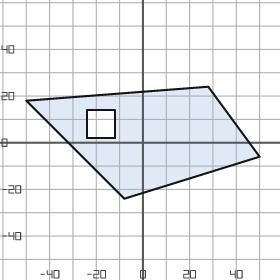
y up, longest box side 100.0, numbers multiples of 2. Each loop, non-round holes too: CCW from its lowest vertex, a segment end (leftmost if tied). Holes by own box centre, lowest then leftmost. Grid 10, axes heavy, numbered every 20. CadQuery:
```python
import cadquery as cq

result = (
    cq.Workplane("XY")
    .moveTo(-8.0, -24.0)
    .lineTo(50.0, -6.0)
    .lineTo(28.0, 24.0)
    .lineTo(-50.0, 18.0)
    .close()
    .moveTo(-24.0, 2.0)
    .lineTo(-12.0, 2.0)
    .lineTo(-12.0, 14.0)
    .lineTo(-24.0, 14.0)
    .close()
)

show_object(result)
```